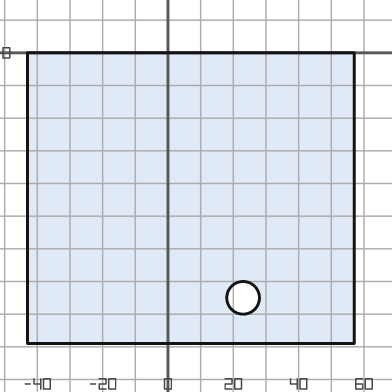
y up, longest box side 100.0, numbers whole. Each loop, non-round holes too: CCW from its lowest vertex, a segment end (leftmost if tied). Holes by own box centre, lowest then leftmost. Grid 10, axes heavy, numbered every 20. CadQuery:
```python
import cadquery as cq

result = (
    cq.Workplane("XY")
    .moveTo(-43.0, -89.0)
    .lineTo(57.0, -89.0)
    .lineTo(57.0, 0.0)
    .lineTo(-43.0, 0.0)
    .close()
    .moveTo(23.0, -75.0)
    .circle(5.0)
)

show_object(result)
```